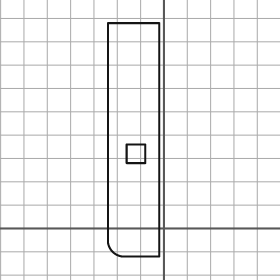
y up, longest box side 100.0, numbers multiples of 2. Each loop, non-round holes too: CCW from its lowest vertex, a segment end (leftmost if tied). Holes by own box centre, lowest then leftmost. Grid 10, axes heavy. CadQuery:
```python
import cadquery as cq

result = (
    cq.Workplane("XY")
    .moveTo(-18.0, -12.0)
    .lineTo(-2.0, -12.0)
    .lineTo(-2.0, 88.0)
    .lineTo(-24.0, 88.0)
    .lineTo(-24.0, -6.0)
    .threePointArc((-22.0, -10.0), (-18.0, -12.0))
    .close()
    .moveTo(-16.0, 28.0)
    .lineTo(-8.0, 28.0)
    .lineTo(-8.0, 36.0)
    .lineTo(-16.0, 36.0)
    .close()
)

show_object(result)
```